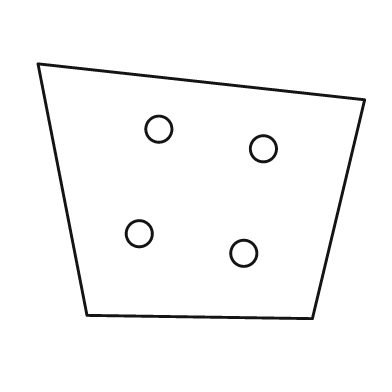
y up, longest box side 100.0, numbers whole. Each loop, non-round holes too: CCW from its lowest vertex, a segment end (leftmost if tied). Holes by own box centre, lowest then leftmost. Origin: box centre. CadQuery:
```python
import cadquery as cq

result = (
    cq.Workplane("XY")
    .moveTo(34.0, -39.0)
    .lineTo(50.0, 28.0)
    .lineTo(-50.0, 39.0)
    .lineTo(-35.0, -38.0)
    .close()
    .moveTo(13.0, -19.0)
    .circle(4.0)
    .moveTo(-19.0, -13.0)
    .circle(4.0)
    .moveTo(19.0, 13.0)
    .circle(4.0)
    .moveTo(-13.0, 19.0)
    .circle(4.0)
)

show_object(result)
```